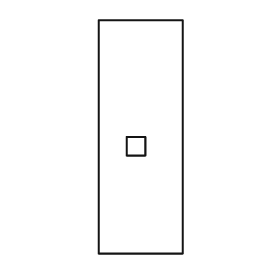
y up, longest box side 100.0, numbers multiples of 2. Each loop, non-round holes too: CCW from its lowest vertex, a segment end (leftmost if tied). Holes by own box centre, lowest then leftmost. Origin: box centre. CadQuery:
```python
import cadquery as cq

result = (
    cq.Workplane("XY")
    .moveTo(-18.0, -50.0)
    .lineTo(18.0, -50.0)
    .lineTo(18.0, 50.0)
    .lineTo(-18.0, 50.0)
    .close()
    .moveTo(-6.0, -8.0)
    .lineTo(2.0, -8.0)
    .lineTo(2.0, 0.0)
    .lineTo(-6.0, 0.0)
    .close()
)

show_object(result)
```